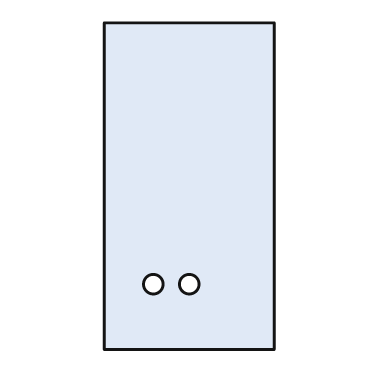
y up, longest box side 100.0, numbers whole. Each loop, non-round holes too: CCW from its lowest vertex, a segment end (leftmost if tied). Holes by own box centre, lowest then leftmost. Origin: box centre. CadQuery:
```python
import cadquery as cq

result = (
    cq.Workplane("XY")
    .moveTo(-26.0, -50.0)
    .lineTo(26.0, -50.0)
    .lineTo(26.0, 50.0)
    .lineTo(-26.0, 50.0)
    .close()
    .moveTo(-11.0, -30.0)
    .circle(3.0)
    .moveTo(0.0, -30.0)
    .circle(3.0)
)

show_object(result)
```